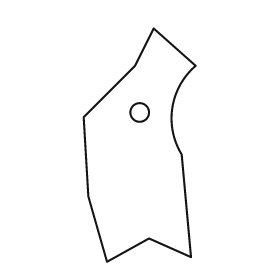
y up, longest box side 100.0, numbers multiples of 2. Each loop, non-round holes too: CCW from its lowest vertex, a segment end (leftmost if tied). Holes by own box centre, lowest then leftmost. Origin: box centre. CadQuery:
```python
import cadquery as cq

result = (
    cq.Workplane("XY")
    .moveTo(-14.0, -50.0)
    .lineTo(4.0, -40.0)
    .lineTo(22.0, -48.0)
    .lineTo(18.0, -4.0)
    .threePointArc((14.0, 16.0), (24.0, 34.0))
    .lineTo(6.0, 50.0)
    .lineTo(-2.0, 34.0)
    .lineTo(-24.0, 12.0)
    .lineTo(-22.0, -22.0)
    .close()
    .moveTo(0.0, 14.0)
    .circle(4.0)
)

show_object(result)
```